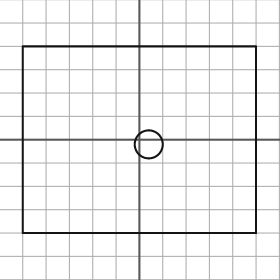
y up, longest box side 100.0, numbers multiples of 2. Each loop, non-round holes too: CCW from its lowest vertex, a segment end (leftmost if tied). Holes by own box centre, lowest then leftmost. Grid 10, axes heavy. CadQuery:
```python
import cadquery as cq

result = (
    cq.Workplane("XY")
    .moveTo(-50.0, -40.0)
    .lineTo(50.0, -40.0)
    .lineTo(50.0, 40.0)
    .lineTo(-50.0, 40.0)
    .close()
    .moveTo(4.0, -2.0)
    .circle(6.0)
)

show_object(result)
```